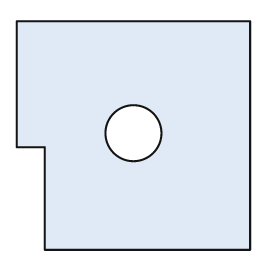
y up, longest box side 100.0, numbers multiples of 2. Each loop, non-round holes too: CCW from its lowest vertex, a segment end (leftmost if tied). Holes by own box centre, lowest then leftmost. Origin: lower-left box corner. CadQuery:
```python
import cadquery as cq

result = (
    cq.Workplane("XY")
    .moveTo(12.0, 0.0)
    .lineTo(100.0, 0.0)
    .lineTo(100.0, 98.0)
    .lineTo(0.0, 98.0)
    .lineTo(0.0, 44.0)
    .lineTo(12.0, 44.0)
    .close()
    .moveTo(50.0, 50.0)
    .circle(12.0)
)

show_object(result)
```